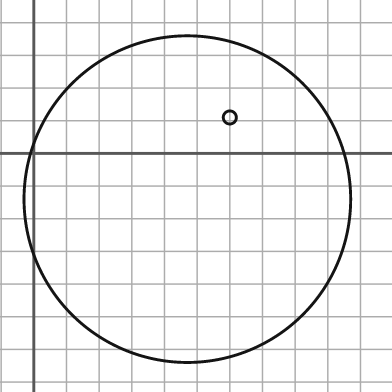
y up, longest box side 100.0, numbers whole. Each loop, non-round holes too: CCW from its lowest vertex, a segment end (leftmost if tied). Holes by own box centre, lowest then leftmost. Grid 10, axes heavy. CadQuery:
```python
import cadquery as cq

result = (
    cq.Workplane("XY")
    .moveTo(47.0, -14.0)
    .circle(50.0)
    .moveTo(60.0, 11.0)
    .circle(2.0)
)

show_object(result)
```